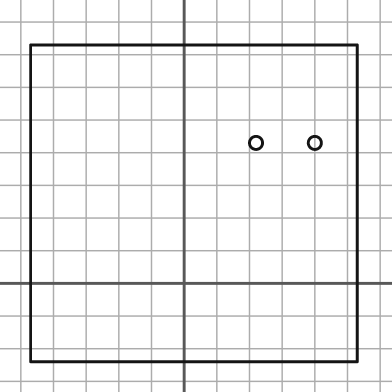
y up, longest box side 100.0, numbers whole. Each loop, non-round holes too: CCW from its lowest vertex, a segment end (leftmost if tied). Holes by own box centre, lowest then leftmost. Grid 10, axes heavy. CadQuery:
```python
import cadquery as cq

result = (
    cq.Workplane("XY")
    .moveTo(-47.0, -24.0)
    .lineTo(53.0, -24.0)
    .lineTo(53.0, 73.0)
    .lineTo(-47.0, 73.0)
    .close()
    .moveTo(22.0, 43.0)
    .circle(2.0)
    .moveTo(40.0, 43.0)
    .circle(2.0)
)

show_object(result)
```